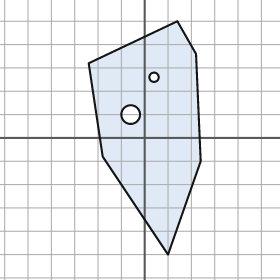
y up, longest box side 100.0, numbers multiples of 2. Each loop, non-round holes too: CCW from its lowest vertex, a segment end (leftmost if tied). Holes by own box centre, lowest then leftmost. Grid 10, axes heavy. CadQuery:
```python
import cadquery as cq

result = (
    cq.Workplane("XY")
    .moveTo(10.0, -50.0)
    .lineTo(24.0, -10.0)
    .lineTo(22.0, 36.0)
    .lineTo(14.0, 50.0)
    .lineTo(-24.0, 32.0)
    .lineTo(-18.0, -8.0)
    .close()
    .moveTo(-6.0, 10.0)
    .circle(4.0)
    .moveTo(4.0, 26.0)
    .circle(2.0)
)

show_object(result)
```